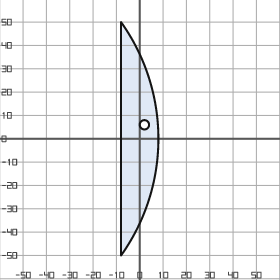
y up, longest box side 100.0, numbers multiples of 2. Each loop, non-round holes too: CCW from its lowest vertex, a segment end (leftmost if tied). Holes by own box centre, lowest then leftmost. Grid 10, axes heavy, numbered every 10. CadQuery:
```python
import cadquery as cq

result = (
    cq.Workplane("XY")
    .moveTo(-8.0, -50.0)
    .threePointArc((8.0, 0.0), (-8.0, 50.0))
    .close()
    .moveTo(2.0, 6.0)
    .circle(2.0)
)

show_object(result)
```